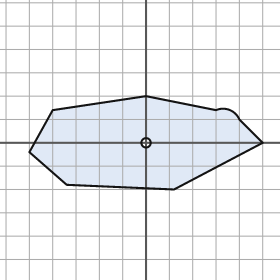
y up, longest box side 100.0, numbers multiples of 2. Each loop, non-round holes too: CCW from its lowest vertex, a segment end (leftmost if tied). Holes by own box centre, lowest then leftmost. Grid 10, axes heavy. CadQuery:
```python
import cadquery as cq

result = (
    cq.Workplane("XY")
    .moveTo(12.0, -20.0)
    .lineTo(50.0, 0.0)
    .lineTo(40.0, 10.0)
    .threePointArc((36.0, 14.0), (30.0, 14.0))
    .lineTo(0.0, 20.0)
    .lineTo(-40.0, 14.0)
    .lineTo(-50.0, -4.0)
    .lineTo(-34.0, -18.0)
    .close()
    .moveTo(0.0, 0.0)
    .circle(2.0)
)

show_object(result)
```